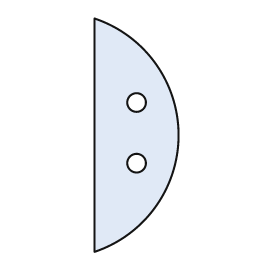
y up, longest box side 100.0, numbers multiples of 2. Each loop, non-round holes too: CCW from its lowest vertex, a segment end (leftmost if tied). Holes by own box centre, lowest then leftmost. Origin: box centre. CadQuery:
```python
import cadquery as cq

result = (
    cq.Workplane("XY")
    .moveTo(-18.0, -50.0)
    .threePointArc((18.0, 0.0), (-18.0, 50.0))
    .close()
    .moveTo(0.0, -12.0)
    .circle(4.0)
    .moveTo(0.0, 14.0)
    .circle(4.0)
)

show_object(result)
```